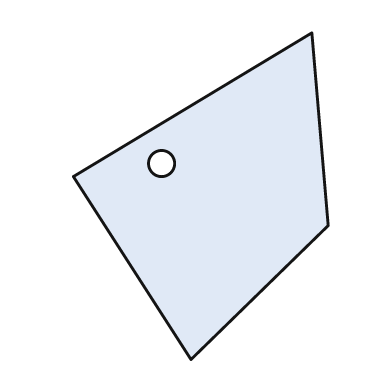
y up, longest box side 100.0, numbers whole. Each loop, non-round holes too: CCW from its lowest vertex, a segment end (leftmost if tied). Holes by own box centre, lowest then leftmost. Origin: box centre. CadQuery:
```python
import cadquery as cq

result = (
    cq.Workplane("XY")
    .moveTo(-3.0, -50.0)
    .lineTo(39.0, -9.0)
    .lineTo(34.0, 50.0)
    .lineTo(-39.0, 6.0)
    .close()
    .moveTo(-12.0, 10.0)
    .circle(4.0)
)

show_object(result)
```